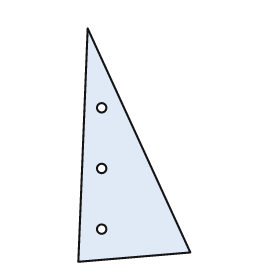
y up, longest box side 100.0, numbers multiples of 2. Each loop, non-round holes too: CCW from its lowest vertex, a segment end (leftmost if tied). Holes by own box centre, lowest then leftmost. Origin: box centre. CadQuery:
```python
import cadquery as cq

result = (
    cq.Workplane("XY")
    .moveTo(-24.0, -50.0)
    .lineTo(24.0, -46.0)
    .lineTo(-20.0, 50.0)
    .close()
    .moveTo(-14.0, -36.0)
    .circle(2.0)
    .moveTo(-14.0, -10.0)
    .circle(2.0)
    .moveTo(-14.0, 16.0)
    .circle(2.0)
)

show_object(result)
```